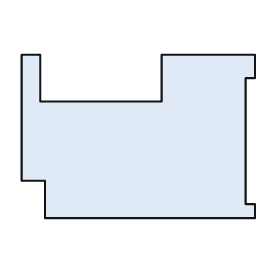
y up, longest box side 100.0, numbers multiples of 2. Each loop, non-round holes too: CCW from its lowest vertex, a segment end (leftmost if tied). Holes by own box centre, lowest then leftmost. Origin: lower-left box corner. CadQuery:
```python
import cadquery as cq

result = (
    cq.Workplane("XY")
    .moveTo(10.0, 0.0)
    .lineTo(100.0, 0.0)
    .lineTo(100.0, 6.0)
    .lineTo(96.0, 6.0)
    .lineTo(96.0, 60.0)
    .lineTo(100.0, 60.0)
    .lineTo(100.0, 70.0)
    .lineTo(60.0, 70.0)
    .lineTo(60.0, 50.0)
    .lineTo(8.0, 50.0)
    .lineTo(8.0, 70.0)
    .lineTo(0.0, 70.0)
    .lineTo(0.0, 16.0)
    .lineTo(10.0, 16.0)
    .close()
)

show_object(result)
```